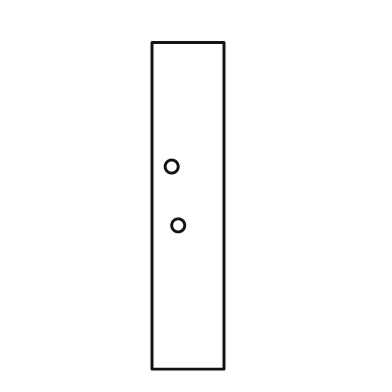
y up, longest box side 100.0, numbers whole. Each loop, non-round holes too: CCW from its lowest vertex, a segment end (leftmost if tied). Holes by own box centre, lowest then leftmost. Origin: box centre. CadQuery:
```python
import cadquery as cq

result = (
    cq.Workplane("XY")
    .moveTo(-11.0, -50.0)
    .lineTo(11.0, -50.0)
    .lineTo(11.0, 50.0)
    .lineTo(-11.0, 50.0)
    .close()
    .moveTo(-3.0, -6.0)
    .circle(2.0)
    .moveTo(-5.0, 12.0)
    .circle(2.0)
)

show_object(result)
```